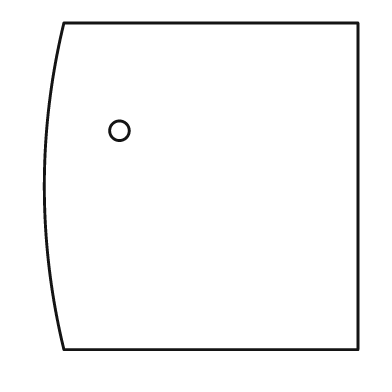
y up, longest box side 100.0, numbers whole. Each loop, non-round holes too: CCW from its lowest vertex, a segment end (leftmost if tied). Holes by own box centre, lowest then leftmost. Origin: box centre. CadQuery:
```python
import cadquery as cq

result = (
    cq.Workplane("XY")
    .moveTo(-42.0, -50.0)
    .lineTo(48.0, -50.0)
    .lineTo(48.0, 50.0)
    .lineTo(-42.0, 50.0)
    .threePointArc((-48.0, 0.0), (-42.0, -50.0))
    .close()
    .moveTo(-25.0, 17.0)
    .circle(3.0)
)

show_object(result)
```